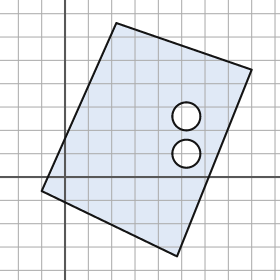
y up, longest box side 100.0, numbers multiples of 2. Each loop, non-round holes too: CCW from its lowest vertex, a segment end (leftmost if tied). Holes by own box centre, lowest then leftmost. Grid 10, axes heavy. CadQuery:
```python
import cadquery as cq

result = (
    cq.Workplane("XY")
    .moveTo(48.0, -34.0)
    .lineTo(80.0, 46.0)
    .lineTo(22.0, 66.0)
    .lineTo(-10.0, -6.0)
    .close()
    .moveTo(52.0, 10.0)
    .circle(6.0)
    .moveTo(52.0, 26.0)
    .circle(6.0)
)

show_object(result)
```